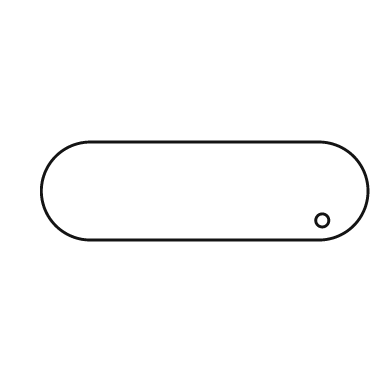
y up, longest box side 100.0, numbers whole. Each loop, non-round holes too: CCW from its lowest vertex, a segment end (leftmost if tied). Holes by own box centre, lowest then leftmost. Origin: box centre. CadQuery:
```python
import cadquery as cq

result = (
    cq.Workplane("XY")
    .moveTo(-35.0, -15.0)
    .lineTo(35.0, -15.0)
    .threePointArc((50.0, 0.0), (35.0, 15.0))
    .lineTo(-35.0, 15.0)
    .threePointArc((-50.0, 0.0), (-35.0, -15.0))
    .close()
    .moveTo(36.0, -9.0)
    .circle(2.0)
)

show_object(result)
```